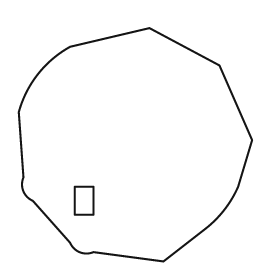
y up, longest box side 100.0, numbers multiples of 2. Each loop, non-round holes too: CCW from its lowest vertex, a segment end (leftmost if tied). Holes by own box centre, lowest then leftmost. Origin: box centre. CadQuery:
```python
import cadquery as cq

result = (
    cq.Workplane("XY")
    .moveTo(12.0, -50.0)
    .lineTo(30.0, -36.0)
    .threePointArc((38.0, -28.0), (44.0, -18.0))
    .lineTo(50.0, 2.0)
    .lineTo(36.0, 34.0)
    .lineTo(6.0, 50.0)
    .lineTo(-28.0, 42.0)
    .threePointArc((-42.0, 30.0), (-50.0, 14.0))
    .lineTo(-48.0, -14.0)
    .threePointArc((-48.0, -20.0), (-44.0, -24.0))
    .lineTo(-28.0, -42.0)
    .threePointArc((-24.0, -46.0), (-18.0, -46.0))
    .close()
    .moveTo(-26.0, -30.0)
    .lineTo(-18.0, -30.0)
    .lineTo(-18.0, -18.0)
    .lineTo(-26.0, -18.0)
    .close()
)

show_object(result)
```